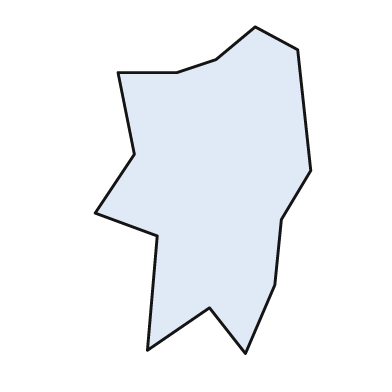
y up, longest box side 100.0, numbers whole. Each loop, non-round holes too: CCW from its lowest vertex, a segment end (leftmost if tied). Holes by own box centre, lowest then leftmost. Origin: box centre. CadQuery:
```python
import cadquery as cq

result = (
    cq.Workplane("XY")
    .moveTo(13.0, -50.0)
    .lineTo(22.0, -29.0)
    .lineTo(24.0, -9.0)
    .lineTo(33.0, 6.0)
    .lineTo(29.0, 43.0)
    .lineTo(16.0, 50.0)
    .lineTo(4.0, 40.0)
    .lineTo(-8.0, 36.0)
    .lineTo(-26.0, 36.0)
    .lineTo(-21.0, 11.0)
    .lineTo(-33.0, -7.0)
    .lineTo(-14.0, -14.0)
    .lineTo(-17.0, -49.0)
    .lineTo(2.0, -36.0)
    .close()
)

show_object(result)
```